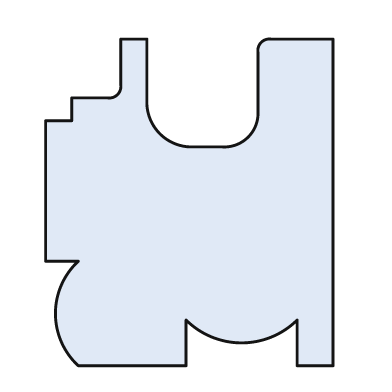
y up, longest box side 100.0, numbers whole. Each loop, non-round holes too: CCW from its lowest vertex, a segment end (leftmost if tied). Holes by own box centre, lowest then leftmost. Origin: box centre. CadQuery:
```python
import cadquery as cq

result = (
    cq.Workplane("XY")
    .moveTo(-34.0, -50.0)
    .lineTo(-1.0, -50.0)
    .lineTo(-1.0, -36.0)
    .threePointArc((16.0, -43.0), (33.0, -36.0))
    .lineTo(33.0, -50.0)
    .lineTo(44.0, -50.0)
    .lineTo(44.0, 50.0)
    .lineTo(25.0, 50.0)
    .threePointArc((22.0, 49.0), (21.0, 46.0))
    .lineTo(21.0, 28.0)
    .threePointArc((18.0, 20.0), (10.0, 17.0))
    .lineTo(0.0, 17.0)
    .threePointArc((-9.0, 21.0), (-13.0, 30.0))
    .lineTo(-13.0, 50.0)
    .lineTo(-21.0, 50.0)
    .lineTo(-21.0, 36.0)
    .threePointArc((-22.0, 33.0), (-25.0, 32.0))
    .lineTo(-36.0, 32.0)
    .lineTo(-36.0, 25.0)
    .lineTo(-44.0, 25.0)
    .lineTo(-44.0, -18.0)
    .lineTo(-34.0, -18.0)
    .threePointArc((-41.0, -34.0), (-34.0, -50.0))
    .close()
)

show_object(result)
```